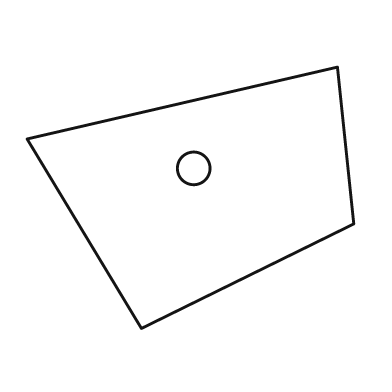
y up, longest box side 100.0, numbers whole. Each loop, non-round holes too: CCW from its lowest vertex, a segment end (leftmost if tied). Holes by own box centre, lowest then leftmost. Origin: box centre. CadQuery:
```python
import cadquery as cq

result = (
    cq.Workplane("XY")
    .moveTo(-15.0, -40.0)
    .lineTo(50.0, -8.0)
    .lineTo(45.0, 40.0)
    .lineTo(-50.0, 18.0)
    .close()
    .moveTo(1.0, 9.0)
    .circle(5.0)
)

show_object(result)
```